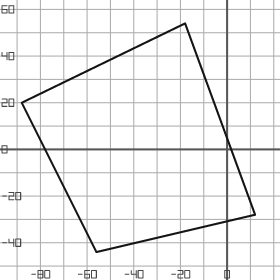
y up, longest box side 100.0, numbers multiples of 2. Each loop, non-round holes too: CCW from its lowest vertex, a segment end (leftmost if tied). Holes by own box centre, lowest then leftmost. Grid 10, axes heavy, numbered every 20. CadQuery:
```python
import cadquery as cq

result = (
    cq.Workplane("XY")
    .moveTo(-56.0, -44.0)
    .lineTo(12.0, -28.0)
    .lineTo(-18.0, 54.0)
    .lineTo(-88.0, 20.0)
    .close()
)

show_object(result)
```